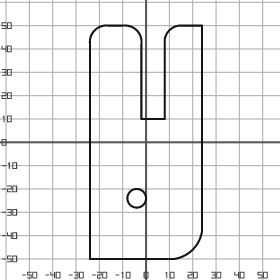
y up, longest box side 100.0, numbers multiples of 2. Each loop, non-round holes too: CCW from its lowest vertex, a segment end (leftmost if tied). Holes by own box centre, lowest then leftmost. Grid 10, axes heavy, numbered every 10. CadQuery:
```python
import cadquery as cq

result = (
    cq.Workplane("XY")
    .moveTo(-24.0, -50.0)
    .lineTo(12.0, -50.0)
    .threePointArc((20.0, -46.0), (24.0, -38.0))
    .lineTo(24.0, 50.0)
    .lineTo(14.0, 50.0)
    .threePointArc((10.0, 48.0), (8.0, 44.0))
    .lineTo(8.0, 10.0)
    .lineTo(-2.0, 10.0)
    .lineTo(-2.0, 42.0)
    .threePointArc((-4.0, 48.0), (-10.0, 50.0))
    .lineTo(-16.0, 50.0)
    .threePointArc((-22.0, 48.0), (-24.0, 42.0))
    .close()
    .moveTo(-4.0, -24.0)
    .circle(4.0)
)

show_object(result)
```